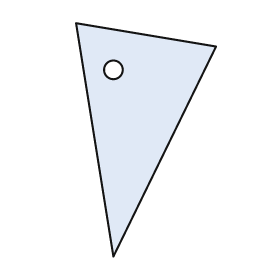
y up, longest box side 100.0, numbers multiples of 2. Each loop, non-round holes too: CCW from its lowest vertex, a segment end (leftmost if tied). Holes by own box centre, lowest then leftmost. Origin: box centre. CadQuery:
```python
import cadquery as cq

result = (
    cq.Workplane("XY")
    .moveTo(-14.0, -50.0)
    .lineTo(30.0, 40.0)
    .lineTo(-30.0, 50.0)
    .close()
    .moveTo(-14.0, 30.0)
    .circle(4.0)
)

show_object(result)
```